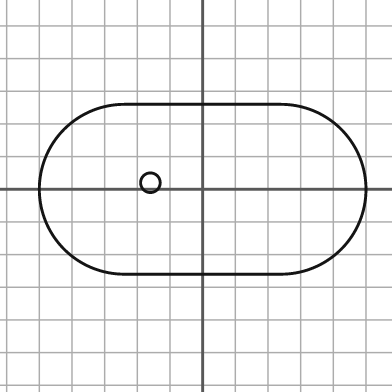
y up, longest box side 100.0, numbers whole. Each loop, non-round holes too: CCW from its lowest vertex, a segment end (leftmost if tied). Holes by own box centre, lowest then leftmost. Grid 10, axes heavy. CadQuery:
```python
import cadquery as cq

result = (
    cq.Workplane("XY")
    .moveTo(-24.0, -26.0)
    .lineTo(24.0, -26.0)
    .threePointArc((50.0, 0.0), (24.0, 26.0))
    .lineTo(-24.0, 26.0)
    .threePointArc((-50.0, 0.0), (-24.0, -26.0))
    .close()
    .moveTo(-16.0, 2.0)
    .circle(3.0)
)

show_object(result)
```